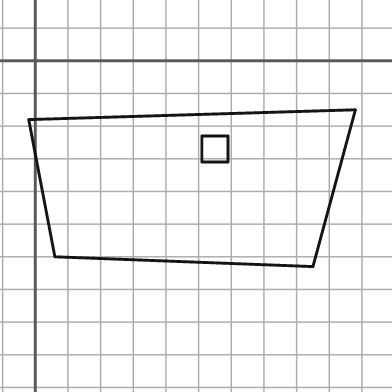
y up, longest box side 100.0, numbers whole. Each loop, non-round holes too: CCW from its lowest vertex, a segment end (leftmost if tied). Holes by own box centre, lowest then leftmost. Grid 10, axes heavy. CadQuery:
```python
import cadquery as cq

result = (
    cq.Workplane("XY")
    .moveTo(85.0, -63.0)
    .lineTo(98.0, -15.0)
    .lineTo(-2.0, -18.0)
    .lineTo(6.0, -60.0)
    .close()
    .moveTo(51.0, -31.0)
    .lineTo(59.0, -31.0)
    .lineTo(59.0, -23.0)
    .lineTo(51.0, -23.0)
    .close()
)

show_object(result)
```